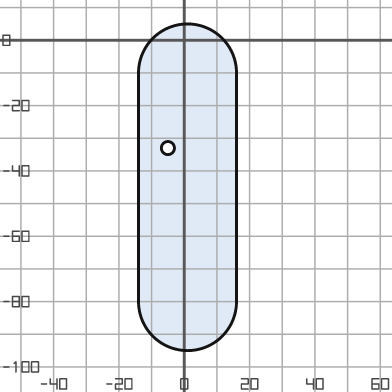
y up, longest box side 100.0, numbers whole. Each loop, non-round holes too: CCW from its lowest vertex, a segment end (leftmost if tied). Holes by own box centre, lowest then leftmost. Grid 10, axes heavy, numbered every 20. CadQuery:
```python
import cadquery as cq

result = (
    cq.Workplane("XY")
    .moveTo(-14.0, -80.0)
    .threePointArc((1.0, -95.0), (16.0, -80.0))
    .lineTo(16.0, -10.0)
    .threePointArc((1.0, 5.0), (-14.0, -10.0))
    .close()
    .moveTo(-5.0, -33.0)
    .circle(2.0)
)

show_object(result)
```